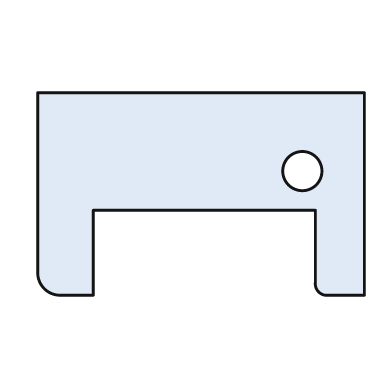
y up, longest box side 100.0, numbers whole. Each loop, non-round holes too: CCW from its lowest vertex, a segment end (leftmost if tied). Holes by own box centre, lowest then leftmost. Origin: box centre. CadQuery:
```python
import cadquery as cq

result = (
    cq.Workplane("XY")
    .moveTo(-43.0, -31.0)
    .lineTo(-33.0, -31.0)
    .lineTo(-33.0, -5.0)
    .lineTo(35.0, -5.0)
    .lineTo(35.0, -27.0)
    .threePointArc((36.0, -30.0), (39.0, -31.0))
    .lineTo(50.0, -31.0)
    .lineTo(50.0, 31.0)
    .lineTo(-50.0, 31.0)
    .lineTo(-50.0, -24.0)
    .threePointArc((-48.0, -29.0), (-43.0, -31.0))
    .close()
    .moveTo(31.0, 7.0)
    .circle(6.0)
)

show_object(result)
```